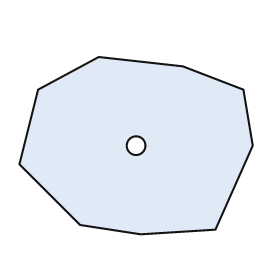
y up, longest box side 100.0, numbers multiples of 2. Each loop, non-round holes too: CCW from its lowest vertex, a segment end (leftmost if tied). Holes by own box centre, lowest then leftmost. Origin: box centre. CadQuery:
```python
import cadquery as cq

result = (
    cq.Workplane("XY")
    .moveTo(2.0, -38.0)
    .lineTo(34.0, -36.0)
    .lineTo(50.0, 0.0)
    .lineTo(46.0, 24.0)
    .lineTo(20.0, 34.0)
    .lineTo(-16.0, 38.0)
    .lineTo(-42.0, 24.0)
    .lineTo(-50.0, -8.0)
    .lineTo(-24.0, -34.0)
    .close()
    .moveTo(0.0, 0.0)
    .circle(4.0)
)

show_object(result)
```